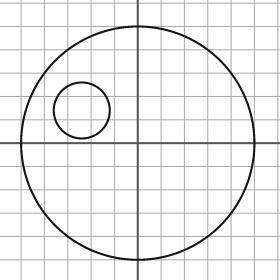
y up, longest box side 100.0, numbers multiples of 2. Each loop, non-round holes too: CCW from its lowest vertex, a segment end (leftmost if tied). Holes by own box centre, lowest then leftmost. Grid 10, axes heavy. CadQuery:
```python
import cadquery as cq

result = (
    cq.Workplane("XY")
    .moveTo(0.0, 0.0)
    .circle(50.0)
    .moveTo(-24.0, 14.0)
    .circle(12.0)
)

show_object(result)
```